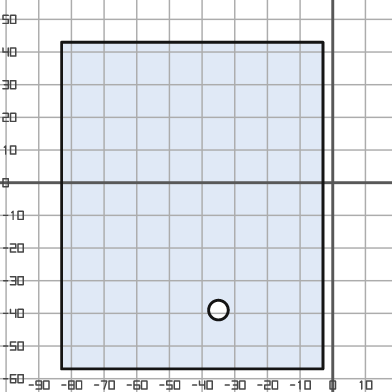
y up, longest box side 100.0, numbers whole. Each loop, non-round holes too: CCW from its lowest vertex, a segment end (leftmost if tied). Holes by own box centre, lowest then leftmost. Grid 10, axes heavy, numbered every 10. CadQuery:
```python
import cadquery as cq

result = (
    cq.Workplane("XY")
    .moveTo(-83.0, -57.0)
    .lineTo(-3.0, -57.0)
    .lineTo(-3.0, 43.0)
    .lineTo(-83.0, 43.0)
    .close()
    .moveTo(-35.0, -39.0)
    .circle(3.0)
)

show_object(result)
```